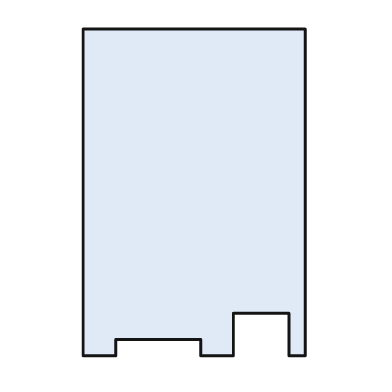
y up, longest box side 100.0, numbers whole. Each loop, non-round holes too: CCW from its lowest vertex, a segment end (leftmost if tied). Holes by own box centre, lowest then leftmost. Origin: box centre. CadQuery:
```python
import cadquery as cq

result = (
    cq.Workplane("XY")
    .moveTo(-34.0, -50.0)
    .lineTo(-24.0, -50.0)
    .lineTo(-24.0, -45.0)
    .lineTo(2.0, -45.0)
    .lineTo(2.0, -50.0)
    .lineTo(12.0, -50.0)
    .lineTo(12.0, -37.0)
    .lineTo(29.0, -37.0)
    .lineTo(29.0, -50.0)
    .lineTo(34.0, -50.0)
    .lineTo(34.0, 50.0)
    .lineTo(-34.0, 50.0)
    .close()
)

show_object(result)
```